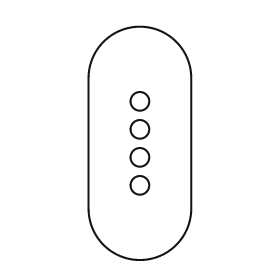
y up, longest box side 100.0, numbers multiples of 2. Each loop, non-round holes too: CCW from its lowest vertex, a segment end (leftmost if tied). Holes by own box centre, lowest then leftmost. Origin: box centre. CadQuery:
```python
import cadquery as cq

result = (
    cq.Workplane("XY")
    .moveTo(-22.0, -28.0)
    .threePointArc((0.0, -50.0), (22.0, -28.0))
    .lineTo(22.0, 28.0)
    .threePointArc((0.0, 50.0), (-22.0, 28.0))
    .close()
    .moveTo(0.0, -18.0)
    .circle(4.0)
    .moveTo(0.0, -6.0)
    .circle(4.0)
    .moveTo(0.0, 6.0)
    .circle(4.0)
    .moveTo(0.0, 18.0)
    .circle(4.0)
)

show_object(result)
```